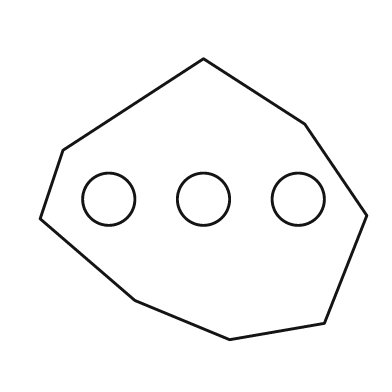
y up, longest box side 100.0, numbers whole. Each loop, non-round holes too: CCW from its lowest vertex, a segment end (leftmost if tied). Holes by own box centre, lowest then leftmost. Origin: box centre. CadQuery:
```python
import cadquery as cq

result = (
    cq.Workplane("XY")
    .moveTo(8.0, -43.0)
    .lineTo(37.0, -38.0)
    .lineTo(50.0, -5.0)
    .lineTo(31.0, 23.0)
    .lineTo(0.0, 43.0)
    .lineTo(-43.0, 15.0)
    .lineTo(-50.0, -6.0)
    .lineTo(-21.0, -31.0)
    .close()
    .moveTo(-29.0, 0.0)
    .circle(8.0)
    .moveTo(0.0, 0.0)
    .circle(8.0)
    .moveTo(29.0, 0.0)
    .circle(8.0)
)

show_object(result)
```